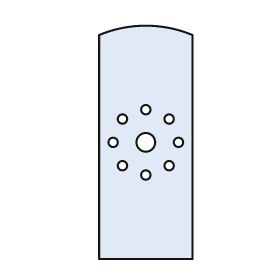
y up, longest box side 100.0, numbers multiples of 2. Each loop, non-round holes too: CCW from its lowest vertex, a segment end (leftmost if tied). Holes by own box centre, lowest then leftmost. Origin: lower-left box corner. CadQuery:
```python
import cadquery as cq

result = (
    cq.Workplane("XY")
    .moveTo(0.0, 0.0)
    .lineTo(40.0, 0.0)
    .lineTo(40.0, 96.0)
    .threePointArc((20.0, 100.0), (0.0, 96.0))
    .close()
    .moveTo(20.0, 36.0)
    .circle(2.0)
    .moveTo(10.0, 40.0)
    .circle(2.0)
    .moveTo(30.0, 40.0)
    .circle(2.0)
    .moveTo(6.0, 50.0)
    .circle(2.0)
    .moveTo(20.0, 50.0)
    .circle(4.0)
    .moveTo(34.0, 50.0)
    .circle(2.0)
    .moveTo(10.0, 60.0)
    .circle(2.0)
    .moveTo(30.0, 60.0)
    .circle(2.0)
    .moveTo(20.0, 64.0)
    .circle(2.0)
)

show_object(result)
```